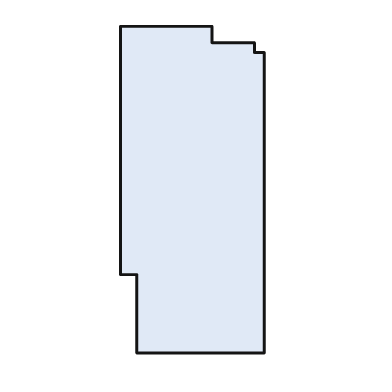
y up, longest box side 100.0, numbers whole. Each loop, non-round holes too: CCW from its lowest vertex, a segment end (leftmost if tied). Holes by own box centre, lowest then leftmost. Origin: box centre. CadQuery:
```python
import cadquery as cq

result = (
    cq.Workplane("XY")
    .moveTo(-17.0, -50.0)
    .lineTo(22.0, -50.0)
    .lineTo(22.0, 42.0)
    .lineTo(19.0, 42.0)
    .lineTo(19.0, 45.0)
    .lineTo(6.0, 45.0)
    .lineTo(6.0, 50.0)
    .lineTo(-22.0, 50.0)
    .lineTo(-22.0, -26.0)
    .lineTo(-17.0, -26.0)
    .close()
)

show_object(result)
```